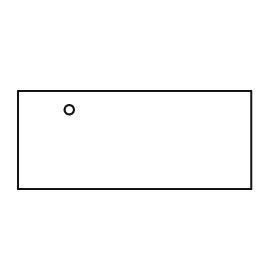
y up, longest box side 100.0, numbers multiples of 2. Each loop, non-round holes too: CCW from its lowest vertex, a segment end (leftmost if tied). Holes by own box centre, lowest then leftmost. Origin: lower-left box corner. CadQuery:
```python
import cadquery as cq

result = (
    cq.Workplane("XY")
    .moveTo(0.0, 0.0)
    .lineTo(100.0, 0.0)
    .lineTo(100.0, 42.0)
    .lineTo(0.0, 42.0)
    .close()
    .moveTo(22.0, 34.0)
    .circle(2.0)
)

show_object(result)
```